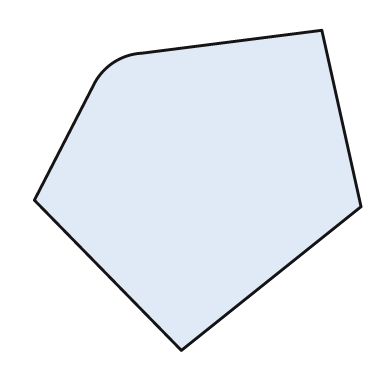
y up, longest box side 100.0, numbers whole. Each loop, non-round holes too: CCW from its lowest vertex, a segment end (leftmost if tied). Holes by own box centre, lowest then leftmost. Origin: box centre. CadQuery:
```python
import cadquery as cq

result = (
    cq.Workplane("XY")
    .moveTo(-5.0, -49.0)
    .lineTo(50.0, -5.0)
    .lineTo(38.0, 49.0)
    .lineTo(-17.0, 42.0)
    .threePointArc((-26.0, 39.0), (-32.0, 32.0))
    .lineTo(-50.0, -3.0)
    .close()
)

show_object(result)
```